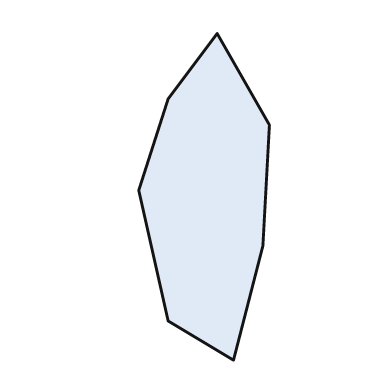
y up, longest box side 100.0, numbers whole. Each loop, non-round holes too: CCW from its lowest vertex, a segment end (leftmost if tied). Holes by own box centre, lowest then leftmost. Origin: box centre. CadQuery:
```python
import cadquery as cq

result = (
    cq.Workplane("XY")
    .moveTo(9.0, -50.0)
    .lineTo(18.0, -15.0)
    .lineTo(20.0, 22.0)
    .lineTo(4.0, 50.0)
    .lineTo(-11.0, 30.0)
    .lineTo(-20.0, 2.0)
    .lineTo(-11.0, -38.0)
    .close()
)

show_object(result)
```